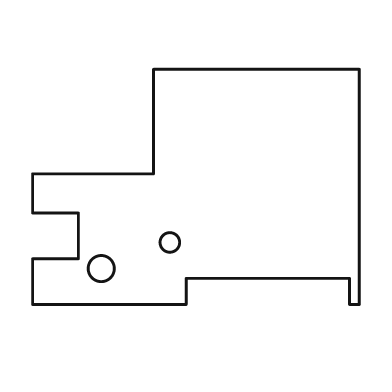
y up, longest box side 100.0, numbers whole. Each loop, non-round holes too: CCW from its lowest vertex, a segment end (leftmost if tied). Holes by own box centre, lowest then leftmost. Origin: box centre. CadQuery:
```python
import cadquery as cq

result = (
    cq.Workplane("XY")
    .moveTo(-50.0, -36.0)
    .lineTo(-3.0, -36.0)
    .lineTo(-3.0, -28.0)
    .lineTo(47.0, -28.0)
    .lineTo(47.0, -36.0)
    .lineTo(50.0, -36.0)
    .lineTo(50.0, 36.0)
    .lineTo(-13.0, 36.0)
    .lineTo(-13.0, 4.0)
    .lineTo(-50.0, 4.0)
    .lineTo(-50.0, -8.0)
    .lineTo(-36.0, -8.0)
    .lineTo(-36.0, -22.0)
    .lineTo(-50.0, -22.0)
    .close()
    .moveTo(-29.0, -25.0)
    .circle(4.0)
    .moveTo(-8.0, -17.0)
    .circle(3.0)
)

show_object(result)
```